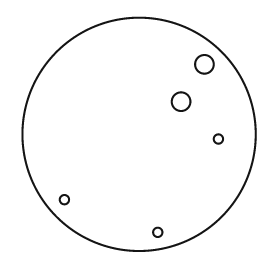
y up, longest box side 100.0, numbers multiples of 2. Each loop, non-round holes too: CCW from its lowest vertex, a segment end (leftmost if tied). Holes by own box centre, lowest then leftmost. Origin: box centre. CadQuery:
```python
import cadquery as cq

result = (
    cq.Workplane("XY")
    .moveTo(0.0, 0.0)
    .circle(50.0)
    .moveTo(8.0, -42.0)
    .circle(2.0)
    .moveTo(-32.0, -28.0)
    .circle(2.0)
    .moveTo(34.0, -2.0)
    .circle(2.0)
    .moveTo(18.0, 14.0)
    .circle(4.0)
    .moveTo(28.0, 30.0)
    .circle(4.0)
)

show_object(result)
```